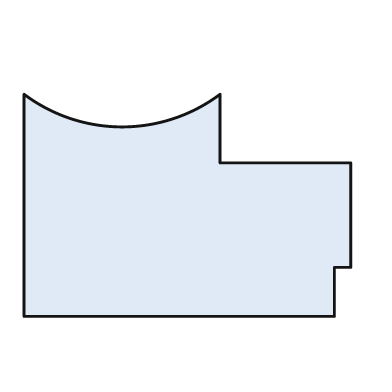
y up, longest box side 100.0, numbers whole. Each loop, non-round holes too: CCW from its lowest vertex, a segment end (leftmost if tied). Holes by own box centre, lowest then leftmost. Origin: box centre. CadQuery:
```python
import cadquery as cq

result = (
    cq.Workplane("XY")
    .moveTo(-50.0, -34.0)
    .lineTo(45.0, -34.0)
    .lineTo(45.0, -19.0)
    .lineTo(50.0, -19.0)
    .lineTo(50.0, 13.0)
    .lineTo(10.0, 13.0)
    .lineTo(10.0, 34.0)
    .threePointArc((-20.0, 24.0), (-50.0, 34.0))
    .close()
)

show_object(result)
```